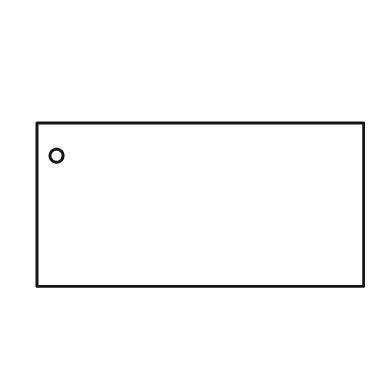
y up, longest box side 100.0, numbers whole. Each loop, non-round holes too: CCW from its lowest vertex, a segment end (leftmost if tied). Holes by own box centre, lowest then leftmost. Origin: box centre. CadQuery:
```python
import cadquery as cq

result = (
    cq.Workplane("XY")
    .moveTo(-50.0, -25.0)
    .lineTo(50.0, -25.0)
    .lineTo(50.0, 25.0)
    .lineTo(-50.0, 25.0)
    .close()
    .moveTo(-44.0, 15.0)
    .circle(2.0)
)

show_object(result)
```